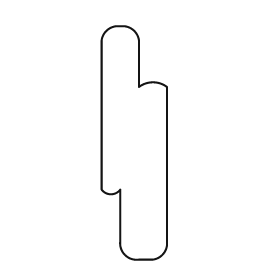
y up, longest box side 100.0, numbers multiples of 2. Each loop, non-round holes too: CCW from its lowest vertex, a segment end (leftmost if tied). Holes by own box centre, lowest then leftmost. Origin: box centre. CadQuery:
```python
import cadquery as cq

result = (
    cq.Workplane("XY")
    .moveTo(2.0, -50.0)
    .lineTo(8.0, -50.0)
    .threePointArc((12.0, -48.0), (14.0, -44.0))
    .lineTo(14.0, 24.0)
    .threePointArc((8.0, 26.0), (2.0, 24.0))
    .lineTo(2.0, 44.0)
    .threePointArc((0.0, 48.0), (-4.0, 50.0))
    .lineTo(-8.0, 50.0)
    .threePointArc((-12.0, 48.0), (-14.0, 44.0))
    .lineTo(-14.0, -20.0)
    .threePointArc((-10.0, -22.0), (-6.0, -20.0))
    .lineTo(-6.0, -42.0)
    .threePointArc((-4.0, -48.0), (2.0, -50.0))
    .close()
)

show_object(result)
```